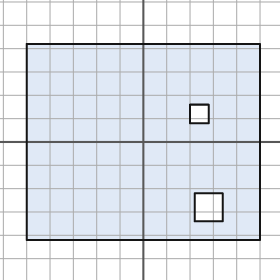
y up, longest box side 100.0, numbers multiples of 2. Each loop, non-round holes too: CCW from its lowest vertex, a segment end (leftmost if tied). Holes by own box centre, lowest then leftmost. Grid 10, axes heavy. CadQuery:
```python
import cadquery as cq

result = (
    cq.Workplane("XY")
    .moveTo(-50.0, -42.0)
    .lineTo(50.0, -42.0)
    .lineTo(50.0, 42.0)
    .lineTo(-50.0, 42.0)
    .close()
    .moveTo(22.0, -34.0)
    .lineTo(34.0, -34.0)
    .lineTo(34.0, -22.0)
    .lineTo(22.0, -22.0)
    .close()
    .moveTo(20.0, 8.0)
    .lineTo(28.0, 8.0)
    .lineTo(28.0, 16.0)
    .lineTo(20.0, 16.0)
    .close()
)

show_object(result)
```